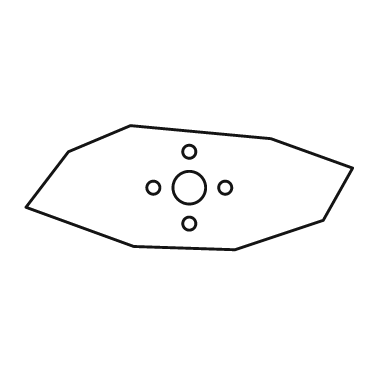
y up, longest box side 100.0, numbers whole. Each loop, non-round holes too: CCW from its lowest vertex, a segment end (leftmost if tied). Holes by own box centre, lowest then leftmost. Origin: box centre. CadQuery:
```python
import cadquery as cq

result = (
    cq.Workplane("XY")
    .moveTo(14.0, -19.0)
    .lineTo(41.0, -10.0)
    .lineTo(50.0, 6.0)
    .lineTo(25.0, 15.0)
    .lineTo(-18.0, 19.0)
    .lineTo(-37.0, 11.0)
    .lineTo(-50.0, -6.0)
    .lineTo(-17.0, -18.0)
    .close()
    .moveTo(0.0, -11.0)
    .circle(2.0)
    .moveTo(-11.0, 0.0)
    .circle(2.0)
    .moveTo(0.0, 0.0)
    .circle(5.0)
    .moveTo(11.0, 0.0)
    .circle(2.0)
    .moveTo(0.0, 11.0)
    .circle(2.0)
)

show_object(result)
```